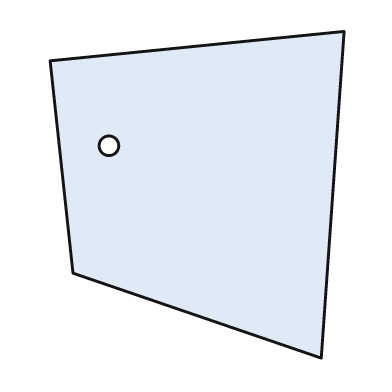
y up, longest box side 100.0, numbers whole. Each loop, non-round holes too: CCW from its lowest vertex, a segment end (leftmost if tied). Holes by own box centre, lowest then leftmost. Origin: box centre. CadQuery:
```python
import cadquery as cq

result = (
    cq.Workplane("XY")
    .moveTo(38.0, -50.0)
    .lineTo(45.0, 50.0)
    .lineTo(-45.0, 41.0)
    .lineTo(-38.0, -24.0)
    .close()
    .moveTo(-27.0, 15.0)
    .circle(3.0)
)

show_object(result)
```